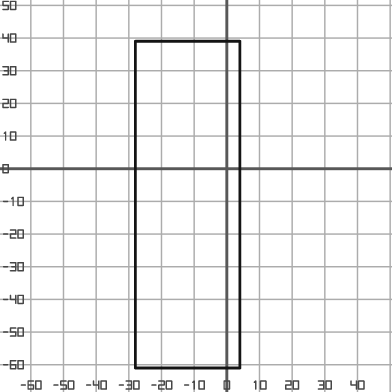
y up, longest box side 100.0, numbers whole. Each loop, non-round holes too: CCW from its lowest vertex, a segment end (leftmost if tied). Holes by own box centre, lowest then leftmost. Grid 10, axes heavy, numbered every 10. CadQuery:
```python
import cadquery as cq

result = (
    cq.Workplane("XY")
    .moveTo(-28.0, -61.0)
    .lineTo(4.0, -61.0)
    .lineTo(4.0, 39.0)
    .lineTo(-28.0, 39.0)
    .close()
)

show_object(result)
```